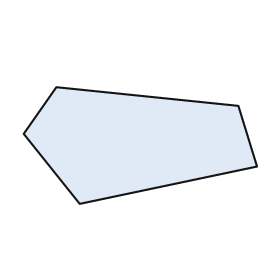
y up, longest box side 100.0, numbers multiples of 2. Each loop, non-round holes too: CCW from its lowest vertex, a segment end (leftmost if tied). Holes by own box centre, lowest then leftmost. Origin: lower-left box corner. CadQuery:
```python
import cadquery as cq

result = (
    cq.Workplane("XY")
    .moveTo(24.0, 0.0)
    .lineTo(100.0, 16.0)
    .lineTo(92.0, 42.0)
    .lineTo(14.0, 50.0)
    .lineTo(0.0, 30.0)
    .close()
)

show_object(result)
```